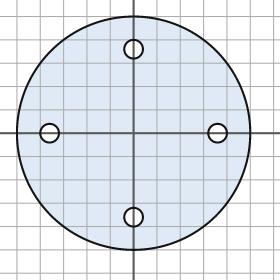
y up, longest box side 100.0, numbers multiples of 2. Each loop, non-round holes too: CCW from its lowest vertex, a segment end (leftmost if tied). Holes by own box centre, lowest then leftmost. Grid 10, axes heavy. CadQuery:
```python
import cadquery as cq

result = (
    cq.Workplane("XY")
    .moveTo(0.0, 0.0)
    .circle(50.0)
    .moveTo(0.0, -36.0)
    .circle(4.0)
    .moveTo(-36.0, 0.0)
    .circle(4.0)
    .moveTo(36.0, 0.0)
    .circle(4.0)
    .moveTo(0.0, 36.0)
    .circle(4.0)
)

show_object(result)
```